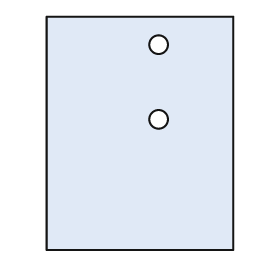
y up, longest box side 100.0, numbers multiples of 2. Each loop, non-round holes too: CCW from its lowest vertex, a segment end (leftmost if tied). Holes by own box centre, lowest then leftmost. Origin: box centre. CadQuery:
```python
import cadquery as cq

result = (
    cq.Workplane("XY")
    .moveTo(-40.0, -50.0)
    .lineTo(40.0, -50.0)
    .lineTo(40.0, 50.0)
    .lineTo(-40.0, 50.0)
    .close()
    .moveTo(8.0, 6.0)
    .circle(4.0)
    .moveTo(8.0, 38.0)
    .circle(4.0)
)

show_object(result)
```